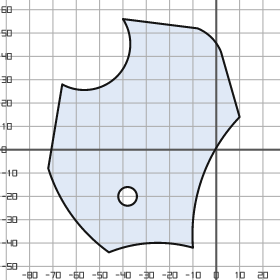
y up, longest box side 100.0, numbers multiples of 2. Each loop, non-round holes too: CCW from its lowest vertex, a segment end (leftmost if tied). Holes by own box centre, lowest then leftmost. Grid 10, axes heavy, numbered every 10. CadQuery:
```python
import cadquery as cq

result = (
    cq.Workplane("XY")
    .moveTo(-46.0, -44.0)
    .threePointArc((-28.0, -40.0), (-10.0, -42.0))
    .threePointArc((-6.0, -12.0), (10.0, 14.0))
    .lineTo(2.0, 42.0)
    .threePointArc((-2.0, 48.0), (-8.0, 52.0))
    .lineTo(-40.0, 56.0)
    .threePointArc((-42.0, 32.0), (-66.0, 28.0))
    .lineTo(-72.0, -8.0)
    .threePointArc((-62.0, -28.0), (-46.0, -44.0))
    .close()
    .moveTo(-38.0, -20.0)
    .circle(4.0)
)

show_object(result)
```